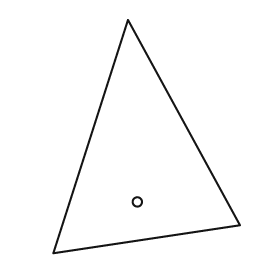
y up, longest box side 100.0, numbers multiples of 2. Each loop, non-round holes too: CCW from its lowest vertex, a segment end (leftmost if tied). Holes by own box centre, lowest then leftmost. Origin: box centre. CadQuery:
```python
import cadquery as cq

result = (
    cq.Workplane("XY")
    .moveTo(-40.0, -50.0)
    .lineTo(40.0, -38.0)
    .lineTo(-8.0, 50.0)
    .close()
    .moveTo(-4.0, -28.0)
    .circle(2.0)
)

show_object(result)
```